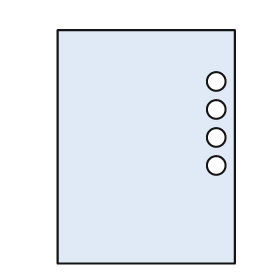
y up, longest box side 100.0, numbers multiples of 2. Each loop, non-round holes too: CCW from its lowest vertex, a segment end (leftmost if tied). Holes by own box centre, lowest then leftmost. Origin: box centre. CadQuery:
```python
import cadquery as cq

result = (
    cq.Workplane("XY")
    .moveTo(-38.0, -50.0)
    .lineTo(38.0, -50.0)
    .lineTo(38.0, 50.0)
    .lineTo(-38.0, 50.0)
    .close()
    .moveTo(30.0, -8.0)
    .circle(4.0)
    .moveTo(30.0, 4.0)
    .circle(4.0)
    .moveTo(30.0, 16.0)
    .circle(4.0)
    .moveTo(30.0, 28.0)
    .circle(4.0)
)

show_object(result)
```